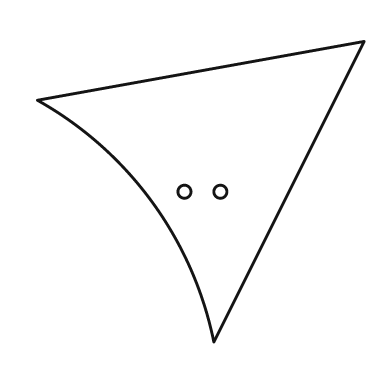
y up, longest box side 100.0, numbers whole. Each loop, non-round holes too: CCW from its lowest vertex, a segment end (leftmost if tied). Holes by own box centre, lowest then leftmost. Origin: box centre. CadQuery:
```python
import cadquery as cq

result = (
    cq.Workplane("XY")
    .moveTo(4.0, -46.0)
    .lineTo(50.0, 46.0)
    .lineTo(-50.0, 28.0)
    .threePointArc((-15.0, -3.0), (4.0, -46.0))
    .close()
    .moveTo(-5.0, 0.0)
    .circle(2.0)
    .moveTo(6.0, 0.0)
    .circle(2.0)
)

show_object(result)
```